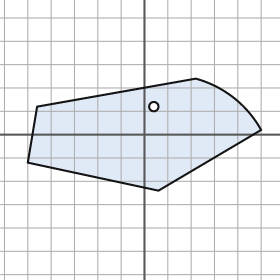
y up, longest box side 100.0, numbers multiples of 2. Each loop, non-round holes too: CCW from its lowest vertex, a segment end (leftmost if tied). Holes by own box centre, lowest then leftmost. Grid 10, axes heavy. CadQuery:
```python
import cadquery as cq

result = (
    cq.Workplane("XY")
    .moveTo(6.0, -24.0)
    .lineTo(50.0, 2.0)
    .threePointArc((38.0, 16.0), (22.0, 24.0))
    .lineTo(-46.0, 12.0)
    .lineTo(-50.0, -12.0)
    .close()
    .moveTo(4.0, 12.0)
    .circle(2.0)
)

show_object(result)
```